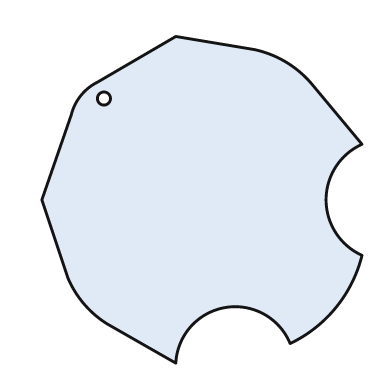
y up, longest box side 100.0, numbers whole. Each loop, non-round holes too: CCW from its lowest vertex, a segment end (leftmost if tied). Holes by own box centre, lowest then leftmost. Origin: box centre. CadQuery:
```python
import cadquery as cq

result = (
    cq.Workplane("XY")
    .moveTo(-8.0, -50.0)
    .threePointArc((7.0, -33.0), (27.0, -44.0))
    .threePointArc((41.0, -33.0), (49.0, -17.0))
    .threePointArc((38.0, 0.0), (49.0, 17.0))
    .lineTo(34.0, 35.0)
    .threePointArc((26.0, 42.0), (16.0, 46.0))
    .lineTo(-8.0, 50.0)
    .lineTo(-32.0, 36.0)
    .threePointArc((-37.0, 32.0), (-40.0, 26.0))
    .lineTo(-49.0, 0.0)
    .lineTo(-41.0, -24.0)
    .threePointArc((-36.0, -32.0), (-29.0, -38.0))
    .close()
    .moveTo(-30.0, 31.0)
    .circle(2.0)
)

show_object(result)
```